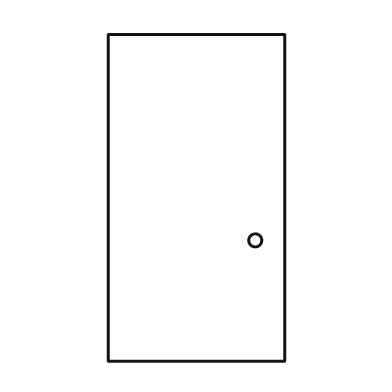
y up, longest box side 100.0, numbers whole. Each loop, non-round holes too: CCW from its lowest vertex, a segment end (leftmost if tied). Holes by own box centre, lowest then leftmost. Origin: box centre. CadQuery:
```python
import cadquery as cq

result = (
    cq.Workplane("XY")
    .moveTo(-27.0, -50.0)
    .lineTo(27.0, -50.0)
    .lineTo(27.0, 50.0)
    .lineTo(-27.0, 50.0)
    .close()
    .moveTo(18.0, -13.0)
    .circle(2.0)
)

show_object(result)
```